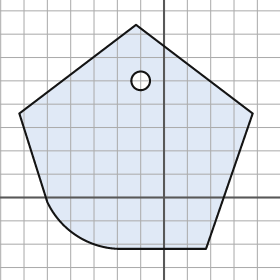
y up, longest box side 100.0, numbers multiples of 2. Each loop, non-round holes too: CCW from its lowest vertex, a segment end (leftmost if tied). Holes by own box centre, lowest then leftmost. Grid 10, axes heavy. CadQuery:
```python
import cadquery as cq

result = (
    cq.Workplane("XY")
    .moveTo(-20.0, -22.0)
    .lineTo(18.0, -22.0)
    .lineTo(38.0, 36.0)
    .lineTo(-12.0, 74.0)
    .lineTo(-62.0, 36.0)
    .lineTo(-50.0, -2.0)
    .threePointArc((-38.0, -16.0), (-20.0, -22.0))
    .close()
    .moveTo(-10.0, 50.0)
    .circle(4.0)
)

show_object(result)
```